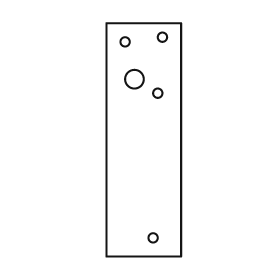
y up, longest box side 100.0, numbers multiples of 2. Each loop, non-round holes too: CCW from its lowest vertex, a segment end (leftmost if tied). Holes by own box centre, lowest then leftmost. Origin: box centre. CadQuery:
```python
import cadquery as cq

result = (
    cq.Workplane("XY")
    .moveTo(-16.0, -50.0)
    .lineTo(16.0, -50.0)
    .lineTo(16.0, 50.0)
    .lineTo(-16.0, 50.0)
    .close()
    .moveTo(4.0, -42.0)
    .circle(2.0)
    .moveTo(6.0, 20.0)
    .circle(2.0)
    .moveTo(-4.0, 26.0)
    .circle(4.0)
    .moveTo(-8.0, 42.0)
    .circle(2.0)
    .moveTo(8.0, 44.0)
    .circle(2.0)
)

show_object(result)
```